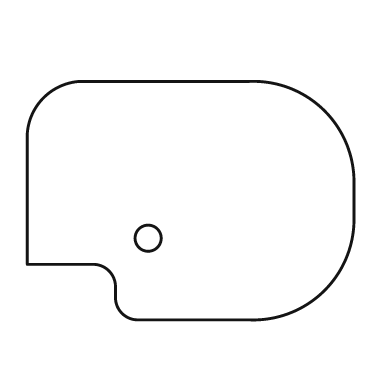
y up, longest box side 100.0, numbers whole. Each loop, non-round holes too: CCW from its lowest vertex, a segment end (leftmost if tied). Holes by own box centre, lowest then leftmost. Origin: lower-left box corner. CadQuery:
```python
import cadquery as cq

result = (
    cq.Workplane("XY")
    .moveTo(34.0, 0.0)
    .lineTo(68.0, 0.0)
    .threePointArc((91.0, 9.0), (100.0, 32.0))
    .lineTo(100.0, 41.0)
    .threePointArc((91.0, 64.0), (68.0, 73.0))
    .lineTo(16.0, 73.0)
    .threePointArc((5.0, 68.0), (0.0, 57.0))
    .lineTo(0.0, 17.0)
    .lineTo(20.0, 17.0)
    .threePointArc((25.0, 15.0), (27.0, 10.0))
    .lineTo(27.0, 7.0)
    .threePointArc((29.0, 2.0), (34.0, 0.0))
    .close()
    .moveTo(37.0, 25.0)
    .circle(4.0)
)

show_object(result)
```